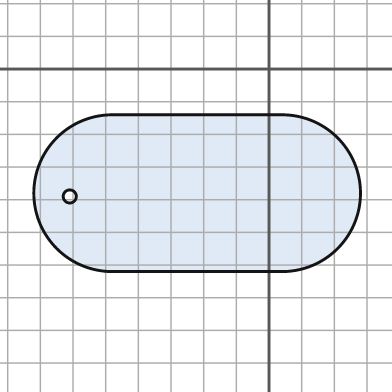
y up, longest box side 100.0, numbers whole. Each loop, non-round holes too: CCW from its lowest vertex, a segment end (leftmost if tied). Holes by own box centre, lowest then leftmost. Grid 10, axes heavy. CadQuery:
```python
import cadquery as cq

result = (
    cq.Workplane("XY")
    .moveTo(-48.0, -62.0)
    .lineTo(4.0, -62.0)
    .threePointArc((28.0, -38.0), (4.0, -14.0))
    .lineTo(-48.0, -14.0)
    .threePointArc((-72.0, -38.0), (-48.0, -62.0))
    .close()
    .moveTo(-61.0, -39.0)
    .circle(2.0)
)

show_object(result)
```